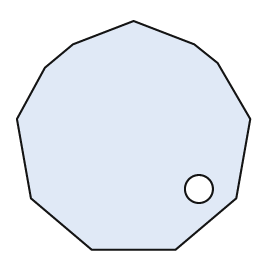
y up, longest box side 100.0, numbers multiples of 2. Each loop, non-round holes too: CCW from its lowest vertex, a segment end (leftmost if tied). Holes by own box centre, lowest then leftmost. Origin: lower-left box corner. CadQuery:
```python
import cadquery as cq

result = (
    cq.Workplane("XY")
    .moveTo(32.0, 0.0)
    .lineTo(68.0, 0.0)
    .lineTo(94.0, 22.0)
    .lineTo(100.0, 56.0)
    .lineTo(86.0, 80.0)
    .lineTo(76.0, 88.0)
    .lineTo(50.0, 98.0)
    .lineTo(24.0, 88.0)
    .lineTo(12.0, 78.0)
    .lineTo(0.0, 56.0)
    .lineTo(6.0, 22.0)
    .close()
    .moveTo(78.0, 26.0)
    .circle(6.0)
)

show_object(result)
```